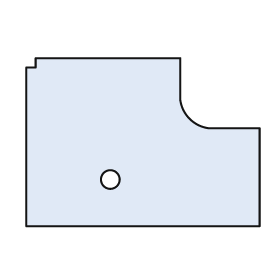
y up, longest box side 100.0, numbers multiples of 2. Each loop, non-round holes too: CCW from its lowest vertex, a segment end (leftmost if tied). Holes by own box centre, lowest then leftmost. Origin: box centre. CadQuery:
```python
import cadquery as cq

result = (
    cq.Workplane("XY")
    .moveTo(-50.0, -36.0)
    .lineTo(50.0, -36.0)
    .lineTo(50.0, 6.0)
    .lineTo(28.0, 6.0)
    .threePointArc((20.0, 10.0), (16.0, 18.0))
    .lineTo(16.0, 36.0)
    .lineTo(-46.0, 36.0)
    .lineTo(-46.0, 32.0)
    .lineTo(-50.0, 32.0)
    .close()
    .moveTo(-14.0, -16.0)
    .circle(4.0)
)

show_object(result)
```